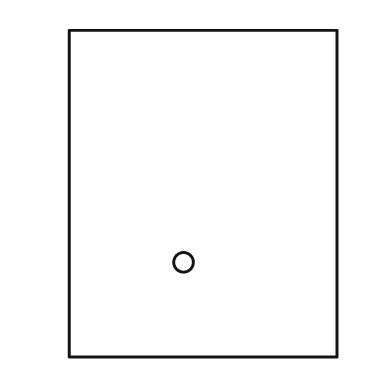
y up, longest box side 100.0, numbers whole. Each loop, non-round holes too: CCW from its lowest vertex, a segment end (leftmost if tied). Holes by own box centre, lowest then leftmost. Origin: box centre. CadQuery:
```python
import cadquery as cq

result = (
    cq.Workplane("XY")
    .moveTo(-41.0, -50.0)
    .lineTo(41.0, -50.0)
    .lineTo(41.0, 50.0)
    .lineTo(-41.0, 50.0)
    .close()
    .moveTo(-6.0, -21.0)
    .circle(3.0)
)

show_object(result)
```